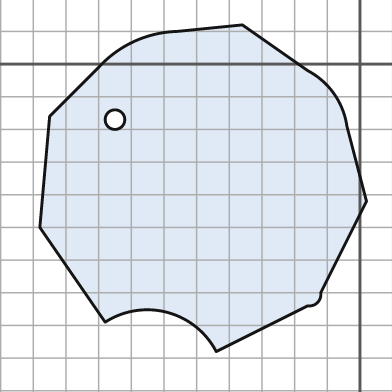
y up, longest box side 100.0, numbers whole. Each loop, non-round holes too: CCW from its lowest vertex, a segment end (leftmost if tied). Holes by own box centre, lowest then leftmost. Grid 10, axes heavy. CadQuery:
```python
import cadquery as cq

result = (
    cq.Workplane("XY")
    .moveTo(-44.0, -88.0)
    .lineTo(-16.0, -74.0)
    .threePointArc((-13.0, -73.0), (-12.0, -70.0))
    .lineTo(2.0, -42.0)
    .lineTo(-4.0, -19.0)
    .threePointArc((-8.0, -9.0), (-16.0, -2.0))
    .lineTo(-36.0, 12.0)
    .lineTo(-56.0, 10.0)
    .threePointArc((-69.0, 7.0), (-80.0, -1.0))
    .lineTo(-95.0, -16.0)
    .lineTo(-98.0, -50.0)
    .lineTo(-78.0, -79.0)
    .threePointArc((-59.0, -76.0), (-44.0, -88.0))
    .close()
    .moveTo(-75.0, -17.0)
    .circle(3.0)
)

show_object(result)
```